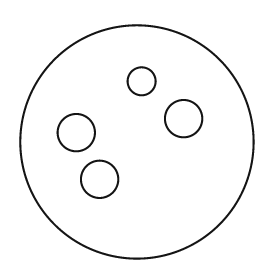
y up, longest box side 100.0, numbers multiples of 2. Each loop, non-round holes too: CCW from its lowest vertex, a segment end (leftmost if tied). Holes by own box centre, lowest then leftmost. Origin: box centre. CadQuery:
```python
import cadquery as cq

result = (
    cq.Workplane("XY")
    .moveTo(0.0, 0.0)
    .circle(50.0)
    .moveTo(-16.0, -16.0)
    .circle(8.0)
    .moveTo(-26.0, 4.0)
    .circle(8.0)
    .moveTo(20.0, 10.0)
    .circle(8.0)
    .moveTo(2.0, 26.0)
    .circle(6.0)
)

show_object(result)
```